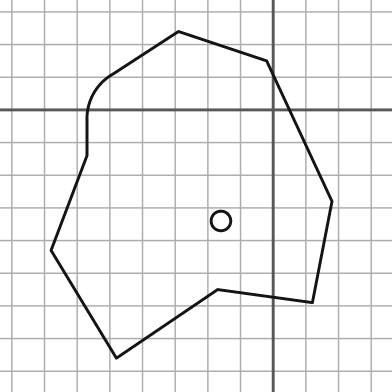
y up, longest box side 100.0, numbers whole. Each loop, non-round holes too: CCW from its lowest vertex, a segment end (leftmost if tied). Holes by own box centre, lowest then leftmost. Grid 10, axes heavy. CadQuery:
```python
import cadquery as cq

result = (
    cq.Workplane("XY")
    .moveTo(-48.0, -76.0)
    .lineTo(-17.0, -55.0)
    .lineTo(12.0, -59.0)
    .lineTo(18.0, -28.0)
    .lineTo(-2.0, 15.0)
    .lineTo(-29.0, 24.0)
    .lineTo(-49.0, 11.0)
    .threePointArc((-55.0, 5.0), (-57.0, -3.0))
    .lineTo(-57.0, -14.0)
    .lineTo(-68.0, -43.0)
    .close()
    .moveTo(-16.0, -34.0)
    .circle(3.0)
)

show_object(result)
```